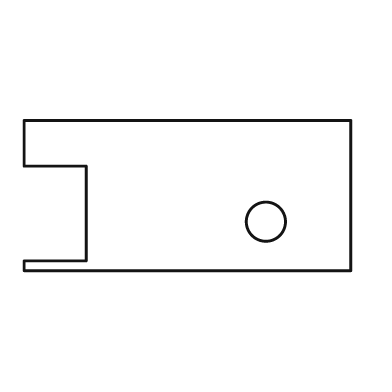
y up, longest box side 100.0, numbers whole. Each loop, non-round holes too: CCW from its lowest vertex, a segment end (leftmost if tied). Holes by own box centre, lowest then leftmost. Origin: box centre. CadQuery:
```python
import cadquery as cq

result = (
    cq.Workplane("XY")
    .moveTo(-50.0, -23.0)
    .lineTo(50.0, -23.0)
    .lineTo(50.0, 23.0)
    .lineTo(-50.0, 23.0)
    .lineTo(-50.0, 9.0)
    .lineTo(-31.0, 9.0)
    .lineTo(-31.0, -20.0)
    .lineTo(-50.0, -20.0)
    .close()
    .moveTo(24.0, -8.0)
    .circle(6.0)
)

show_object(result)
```